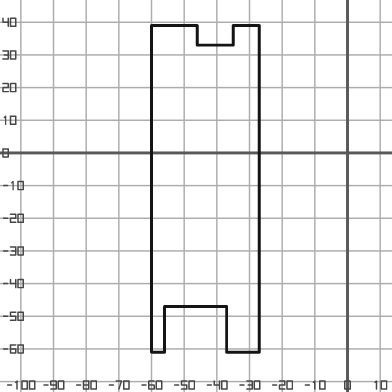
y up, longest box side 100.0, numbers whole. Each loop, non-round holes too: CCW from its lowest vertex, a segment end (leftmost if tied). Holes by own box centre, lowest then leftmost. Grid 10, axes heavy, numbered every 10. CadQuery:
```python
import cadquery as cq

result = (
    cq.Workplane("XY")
    .moveTo(-60.0, -61.0)
    .lineTo(-56.0, -61.0)
    .lineTo(-56.0, -47.0)
    .lineTo(-37.0, -47.0)
    .lineTo(-37.0, -61.0)
    .lineTo(-27.0, -61.0)
    .lineTo(-27.0, 39.0)
    .lineTo(-35.0, 39.0)
    .lineTo(-35.0, 33.0)
    .lineTo(-46.0, 33.0)
    .lineTo(-46.0, 39.0)
    .lineTo(-60.0, 39.0)
    .close()
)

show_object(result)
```